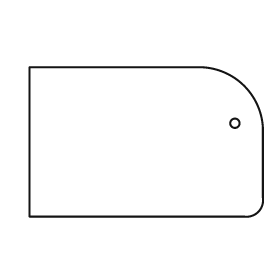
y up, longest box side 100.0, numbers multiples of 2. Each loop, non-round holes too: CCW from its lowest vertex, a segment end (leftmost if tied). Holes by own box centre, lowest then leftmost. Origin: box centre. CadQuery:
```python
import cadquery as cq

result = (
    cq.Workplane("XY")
    .moveTo(-50.0, -32.0)
    .lineTo(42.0, -32.0)
    .threePointArc((48.0, -30.0), (50.0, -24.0))
    .lineTo(50.0, 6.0)
    .threePointArc((42.0, 24.0), (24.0, 32.0))
    .lineTo(-50.0, 32.0)
    .close()
    .moveTo(38.0, 8.0)
    .circle(2.0)
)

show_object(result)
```